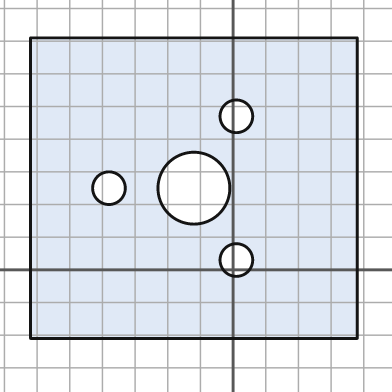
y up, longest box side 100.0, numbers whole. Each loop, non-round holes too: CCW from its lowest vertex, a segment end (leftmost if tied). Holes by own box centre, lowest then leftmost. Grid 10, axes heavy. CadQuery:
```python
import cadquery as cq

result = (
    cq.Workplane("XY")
    .moveTo(-62.0, -21.0)
    .lineTo(38.0, -21.0)
    .lineTo(38.0, 71.0)
    .lineTo(-62.0, 71.0)
    .close()
    .moveTo(1.0, 3.0)
    .circle(5.0)
    .moveTo(-38.0, 25.0)
    .circle(5.0)
    .moveTo(-12.0, 25.0)
    .circle(11.0)
    .moveTo(1.0, 47.0)
    .circle(5.0)
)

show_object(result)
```